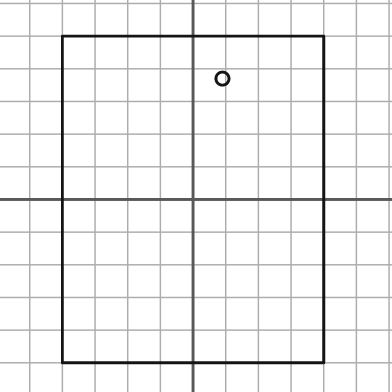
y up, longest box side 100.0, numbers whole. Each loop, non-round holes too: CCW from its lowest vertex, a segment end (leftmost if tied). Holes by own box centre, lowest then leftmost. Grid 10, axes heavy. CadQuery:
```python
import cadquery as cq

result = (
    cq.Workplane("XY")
    .moveTo(-40.0, -50.0)
    .lineTo(40.0, -50.0)
    .lineTo(40.0, 50.0)
    .lineTo(-40.0, 50.0)
    .close()
    .moveTo(9.0, 37.0)
    .circle(2.0)
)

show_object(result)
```